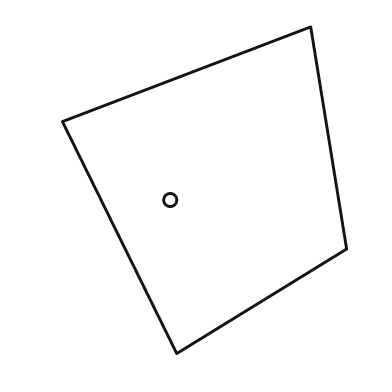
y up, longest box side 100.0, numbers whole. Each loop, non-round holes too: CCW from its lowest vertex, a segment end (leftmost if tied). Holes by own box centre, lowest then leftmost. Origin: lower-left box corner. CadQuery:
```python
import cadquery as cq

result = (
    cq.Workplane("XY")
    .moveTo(35.0, 0.0)
    .lineTo(87.0, 32.0)
    .lineTo(76.0, 100.0)
    .lineTo(0.0, 71.0)
    .close()
    .moveTo(33.0, 47.0)
    .circle(2.0)
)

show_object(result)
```